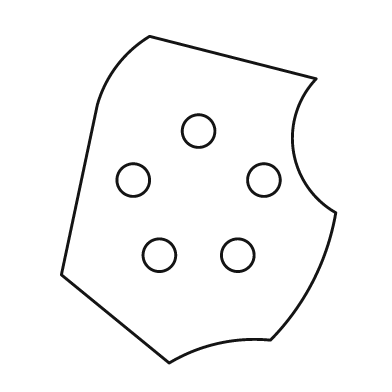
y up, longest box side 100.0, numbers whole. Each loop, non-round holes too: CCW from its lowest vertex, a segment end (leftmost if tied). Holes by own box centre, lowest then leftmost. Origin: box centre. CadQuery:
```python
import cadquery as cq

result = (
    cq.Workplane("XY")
    .moveTo(-9.0, -50.0)
    .threePointArc((6.0, -44.0), (22.0, -43.0))
    .threePointArc((35.0, -25.0), (42.0, -4.0))
    .threePointArc((29.0, 15.0), (36.0, 37.0))
    .lineTo(-15.0, 50.0)
    .threePointArc((-25.0, 41.0), (-31.0, 29.0))
    .lineTo(-42.0, -23.0)
    .close()
    .moveTo(-12.0, -17.0)
    .circle(5.0)
    .moveTo(12.0, -17.0)
    .circle(5.0)
    .moveTo(-20.0, 6.0)
    .circle(5.0)
    .moveTo(20.0, 6.0)
    .circle(5.0)
    .moveTo(0.0, 21.0)
    .circle(5.0)
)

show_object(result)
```